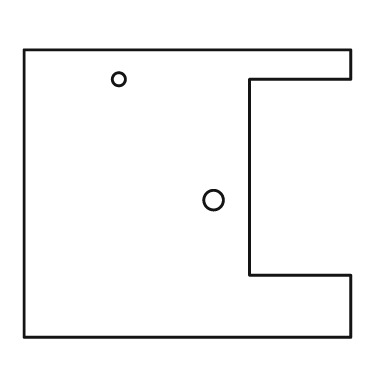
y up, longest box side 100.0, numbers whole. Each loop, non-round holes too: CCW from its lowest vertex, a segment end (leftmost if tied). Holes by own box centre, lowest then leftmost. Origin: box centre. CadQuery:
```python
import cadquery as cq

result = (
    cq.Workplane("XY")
    .moveTo(-50.0, -44.0)
    .lineTo(50.0, -44.0)
    .lineTo(50.0, -25.0)
    .lineTo(19.0, -25.0)
    .lineTo(19.0, 35.0)
    .lineTo(50.0, 35.0)
    .lineTo(50.0, 44.0)
    .lineTo(-50.0, 44.0)
    .close()
    .moveTo(8.0, -2.0)
    .circle(3.0)
    .moveTo(-21.0, 35.0)
    .circle(2.0)
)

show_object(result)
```